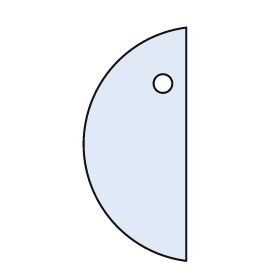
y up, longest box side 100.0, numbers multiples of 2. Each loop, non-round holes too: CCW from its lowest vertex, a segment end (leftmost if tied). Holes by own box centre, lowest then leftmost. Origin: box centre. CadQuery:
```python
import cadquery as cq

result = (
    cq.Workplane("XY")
    .moveTo(22.0, -50.0)
    .lineTo(22.0, 50.0)
    .threePointArc((-22.0, 0.0), (22.0, -50.0))
    .close()
    .moveTo(12.0, 26.0)
    .circle(4.0)
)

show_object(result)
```